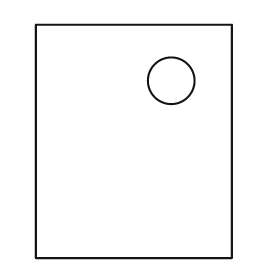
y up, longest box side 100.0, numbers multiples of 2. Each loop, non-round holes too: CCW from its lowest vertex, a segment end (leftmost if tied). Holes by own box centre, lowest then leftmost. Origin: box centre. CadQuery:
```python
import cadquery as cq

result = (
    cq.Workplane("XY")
    .moveTo(-42.0, -50.0)
    .lineTo(42.0, -50.0)
    .lineTo(42.0, 50.0)
    .lineTo(-42.0, 50.0)
    .close()
    .moveTo(16.0, 26.0)
    .circle(10.0)
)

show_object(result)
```